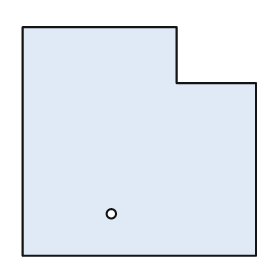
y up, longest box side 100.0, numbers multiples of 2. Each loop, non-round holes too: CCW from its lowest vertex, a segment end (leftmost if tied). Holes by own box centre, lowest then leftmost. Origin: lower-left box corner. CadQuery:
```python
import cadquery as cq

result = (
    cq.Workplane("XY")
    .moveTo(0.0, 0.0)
    .lineTo(100.0, 0.0)
    .lineTo(100.0, 74.0)
    .lineTo(66.0, 74.0)
    .lineTo(66.0, 98.0)
    .lineTo(0.0, 98.0)
    .close()
    .moveTo(38.0, 18.0)
    .circle(2.0)
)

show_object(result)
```